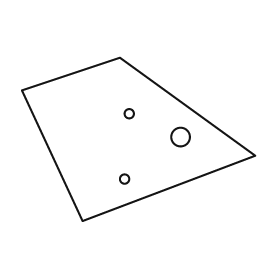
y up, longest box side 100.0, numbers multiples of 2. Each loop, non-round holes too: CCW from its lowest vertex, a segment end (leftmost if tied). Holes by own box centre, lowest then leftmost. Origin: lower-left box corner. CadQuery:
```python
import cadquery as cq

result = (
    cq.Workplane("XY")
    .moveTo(26.0, 0.0)
    .lineTo(100.0, 28.0)
    .lineTo(42.0, 70.0)
    .lineTo(0.0, 56.0)
    .close()
    .moveTo(44.0, 18.0)
    .circle(2.0)
    .moveTo(68.0, 36.0)
    .circle(4.0)
    .moveTo(46.0, 46.0)
    .circle(2.0)
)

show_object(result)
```